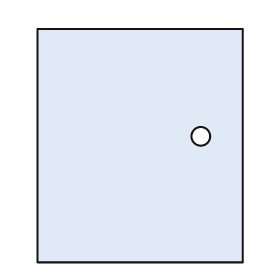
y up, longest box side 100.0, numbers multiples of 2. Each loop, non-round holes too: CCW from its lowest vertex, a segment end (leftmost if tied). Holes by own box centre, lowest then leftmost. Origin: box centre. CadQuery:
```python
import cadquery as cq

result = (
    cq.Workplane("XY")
    .moveTo(-44.0, -50.0)
    .lineTo(44.0, -50.0)
    .lineTo(44.0, 50.0)
    .lineTo(-44.0, 50.0)
    .close()
    .moveTo(26.0, 4.0)
    .circle(4.0)
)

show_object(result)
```